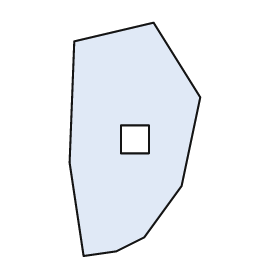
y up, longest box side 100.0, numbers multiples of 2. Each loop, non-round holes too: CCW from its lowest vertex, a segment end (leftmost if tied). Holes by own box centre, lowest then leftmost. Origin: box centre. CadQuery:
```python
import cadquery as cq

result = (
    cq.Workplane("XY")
    .moveTo(-22.0, -50.0)
    .lineTo(-8.0, -48.0)
    .lineTo(4.0, -42.0)
    .lineTo(20.0, -20.0)
    .lineTo(28.0, 18.0)
    .lineTo(8.0, 50.0)
    .lineTo(-26.0, 42.0)
    .lineTo(-28.0, -10.0)
    .close()
    .moveTo(-6.0, -6.0)
    .lineTo(6.0, -6.0)
    .lineTo(6.0, 6.0)
    .lineTo(-6.0, 6.0)
    .close()
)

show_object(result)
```